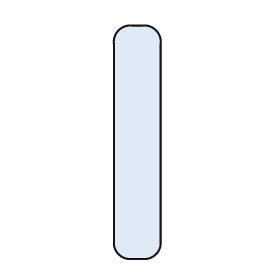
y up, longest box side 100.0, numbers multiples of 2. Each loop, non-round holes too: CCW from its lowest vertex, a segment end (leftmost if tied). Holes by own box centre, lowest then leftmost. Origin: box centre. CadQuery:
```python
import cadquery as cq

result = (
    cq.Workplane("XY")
    .moveTo(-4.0, -50.0)
    .lineTo(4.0, -50.0)
    .threePointArc((8.0, -48.0), (10.0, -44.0))
    .lineTo(10.0, 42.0)
    .threePointArc((8.0, 48.0), (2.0, 50.0))
    .lineTo(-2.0, 50.0)
    .threePointArc((-8.0, 48.0), (-10.0, 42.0))
    .lineTo(-10.0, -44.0)
    .threePointArc((-8.0, -48.0), (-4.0, -50.0))
    .close()
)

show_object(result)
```